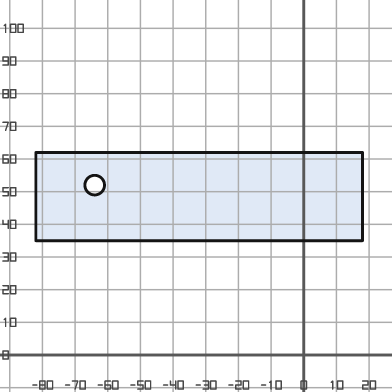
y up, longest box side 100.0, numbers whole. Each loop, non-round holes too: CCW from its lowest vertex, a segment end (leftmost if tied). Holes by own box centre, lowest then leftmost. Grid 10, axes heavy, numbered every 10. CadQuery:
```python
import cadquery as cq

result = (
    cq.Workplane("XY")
    .moveTo(-82.0, 35.0)
    .lineTo(18.0, 35.0)
    .lineTo(18.0, 62.0)
    .lineTo(-82.0, 62.0)
    .close()
    .moveTo(-64.0, 52.0)
    .circle(3.0)
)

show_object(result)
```